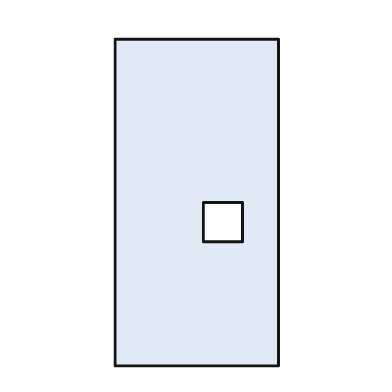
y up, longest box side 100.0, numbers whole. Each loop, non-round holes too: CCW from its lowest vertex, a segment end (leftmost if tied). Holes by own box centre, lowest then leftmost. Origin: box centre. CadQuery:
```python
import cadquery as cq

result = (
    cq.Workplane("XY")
    .moveTo(-25.0, -50.0)
    .lineTo(25.0, -50.0)
    .lineTo(25.0, 50.0)
    .lineTo(-25.0, 50.0)
    .close()
    .moveTo(2.0, -12.0)
    .lineTo(14.0, -12.0)
    .lineTo(14.0, 0.0)
    .lineTo(2.0, 0.0)
    .close()
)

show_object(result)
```